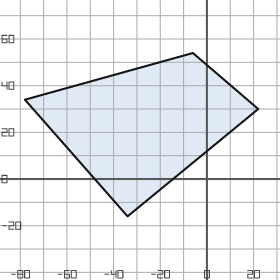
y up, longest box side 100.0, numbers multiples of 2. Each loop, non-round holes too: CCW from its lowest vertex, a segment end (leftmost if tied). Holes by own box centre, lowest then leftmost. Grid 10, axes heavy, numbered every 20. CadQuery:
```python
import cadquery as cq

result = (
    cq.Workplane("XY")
    .moveTo(-34.0, -16.0)
    .lineTo(22.0, 30.0)
    .lineTo(-6.0, 54.0)
    .lineTo(-78.0, 34.0)
    .close()
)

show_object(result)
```